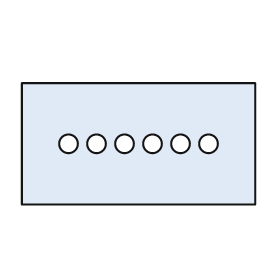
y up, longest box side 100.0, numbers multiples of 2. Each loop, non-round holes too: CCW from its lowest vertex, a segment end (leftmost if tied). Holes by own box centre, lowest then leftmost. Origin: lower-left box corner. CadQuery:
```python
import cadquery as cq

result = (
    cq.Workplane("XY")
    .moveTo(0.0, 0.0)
    .lineTo(100.0, 0.0)
    .lineTo(100.0, 52.0)
    .lineTo(0.0, 52.0)
    .close()
    .moveTo(20.0, 26.0)
    .circle(4.0)
    .moveTo(32.0, 26.0)
    .circle(4.0)
    .moveTo(44.0, 26.0)
    .circle(4.0)
    .moveTo(56.0, 26.0)
    .circle(4.0)
    .moveTo(68.0, 26.0)
    .circle(4.0)
    .moveTo(80.0, 26.0)
    .circle(4.0)
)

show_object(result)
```